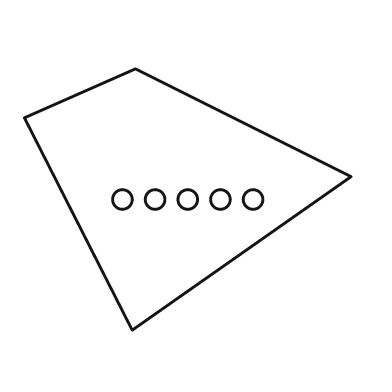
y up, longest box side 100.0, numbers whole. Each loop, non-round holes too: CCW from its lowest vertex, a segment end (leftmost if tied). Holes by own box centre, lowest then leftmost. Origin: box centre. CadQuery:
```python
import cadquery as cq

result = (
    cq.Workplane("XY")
    .moveTo(-17.0, -40.0)
    .lineTo(50.0, 7.0)
    .lineTo(-16.0, 40.0)
    .lineTo(-50.0, 25.0)
    .close()
    .moveTo(-20.0, 0.0)
    .circle(3.0)
    .moveTo(-10.0, 0.0)
    .circle(3.0)
    .moveTo(0.0, 0.0)
    .circle(3.0)
    .moveTo(10.0, 0.0)
    .circle(3.0)
    .moveTo(20.0, 0.0)
    .circle(3.0)
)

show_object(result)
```